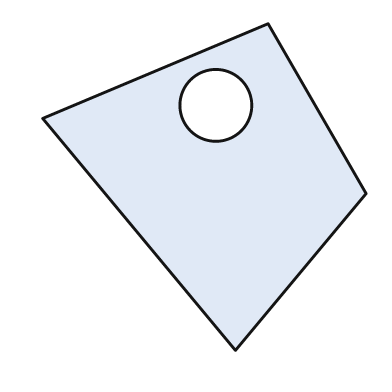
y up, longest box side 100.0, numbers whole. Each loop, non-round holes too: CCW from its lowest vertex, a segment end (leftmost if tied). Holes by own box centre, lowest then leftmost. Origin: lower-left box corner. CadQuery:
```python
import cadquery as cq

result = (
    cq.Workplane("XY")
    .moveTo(59.0, 0.0)
    .lineTo(99.0, 48.0)
    .lineTo(69.0, 100.0)
    .lineTo(0.0, 71.0)
    .close()
    .moveTo(53.0, 75.0)
    .circle(11.0)
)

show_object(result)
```